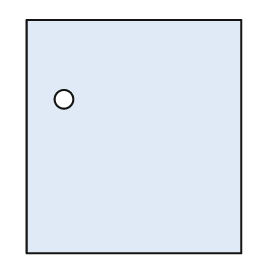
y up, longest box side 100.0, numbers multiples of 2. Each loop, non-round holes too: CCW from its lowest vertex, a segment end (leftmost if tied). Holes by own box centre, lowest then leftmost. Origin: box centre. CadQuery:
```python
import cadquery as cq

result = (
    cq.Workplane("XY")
    .moveTo(-46.0, -50.0)
    .lineTo(46.0, -50.0)
    .lineTo(46.0, 50.0)
    .lineTo(-46.0, 50.0)
    .close()
    .moveTo(-30.0, 16.0)
    .circle(4.0)
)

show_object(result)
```